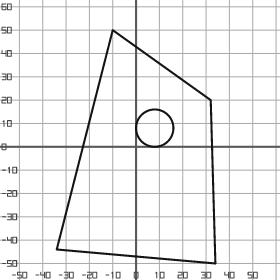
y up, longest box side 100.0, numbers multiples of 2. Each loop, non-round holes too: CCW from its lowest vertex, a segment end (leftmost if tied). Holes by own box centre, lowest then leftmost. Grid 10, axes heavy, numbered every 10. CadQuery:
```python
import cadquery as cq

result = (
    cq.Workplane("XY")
    .moveTo(34.0, -50.0)
    .lineTo(32.0, 20.0)
    .lineTo(-10.0, 50.0)
    .lineTo(-34.0, -44.0)
    .close()
    .moveTo(8.0, 8.0)
    .circle(8.0)
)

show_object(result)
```